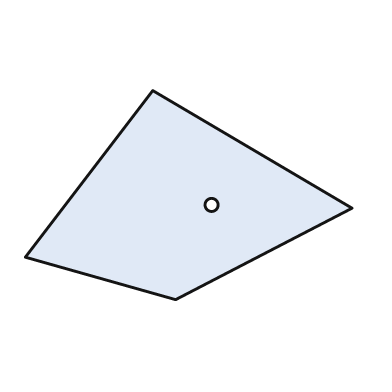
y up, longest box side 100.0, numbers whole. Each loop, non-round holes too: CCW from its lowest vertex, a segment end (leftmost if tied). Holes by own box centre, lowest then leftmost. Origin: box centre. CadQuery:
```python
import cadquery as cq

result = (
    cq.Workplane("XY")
    .moveTo(-4.0, -32.0)
    .lineTo(50.0, -4.0)
    .lineTo(-11.0, 32.0)
    .lineTo(-50.0, -19.0)
    .close()
    .moveTo(7.0, -3.0)
    .circle(2.0)
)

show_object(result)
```